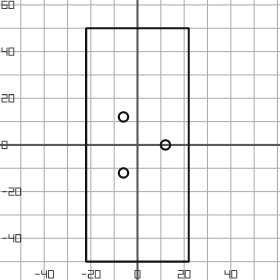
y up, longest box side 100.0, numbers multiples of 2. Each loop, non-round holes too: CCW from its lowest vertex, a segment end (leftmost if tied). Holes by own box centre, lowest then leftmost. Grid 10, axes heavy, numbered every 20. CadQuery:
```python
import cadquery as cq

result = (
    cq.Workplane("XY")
    .moveTo(-22.0, -50.0)
    .lineTo(22.0, -50.0)
    .lineTo(22.0, 50.0)
    .lineTo(-22.0, 50.0)
    .close()
    .moveTo(-6.0, -12.0)
    .circle(2.0)
    .moveTo(12.0, 0.0)
    .circle(2.0)
    .moveTo(-6.0, 12.0)
    .circle(2.0)
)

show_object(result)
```